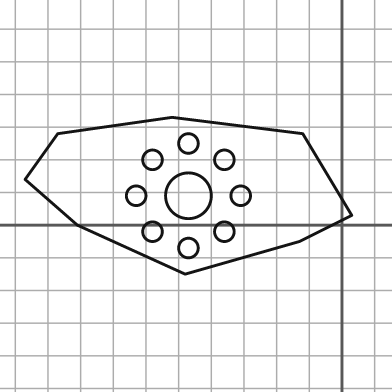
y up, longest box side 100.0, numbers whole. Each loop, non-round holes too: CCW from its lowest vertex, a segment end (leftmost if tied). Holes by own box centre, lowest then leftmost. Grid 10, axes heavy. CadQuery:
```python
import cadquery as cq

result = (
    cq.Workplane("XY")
    .moveTo(-48.0, -15.0)
    .lineTo(-13.0, -5.0)
    .lineTo(3.0, 3.0)
    .lineTo(-12.0, 28.0)
    .lineTo(-52.0, 33.0)
    .lineTo(-87.0, 28.0)
    .lineTo(-97.0, 14.0)
    .lineTo(-81.0, 0.0)
    .close()
    .moveTo(-47.0, -7.0)
    .circle(3.0)
    .moveTo(-58.0, -2.0)
    .circle(3.0)
    .moveTo(-36.0, -2.0)
    .circle(3.0)
    .moveTo(-63.0, 9.0)
    .circle(3.0)
    .moveTo(-47.0, 9.0)
    .circle(7.0)
    .moveTo(-31.0, 9.0)
    .circle(3.0)
    .moveTo(-58.0, 20.0)
    .circle(3.0)
    .moveTo(-36.0, 20.0)
    .circle(3.0)
    .moveTo(-47.0, 25.0)
    .circle(3.0)
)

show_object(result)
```